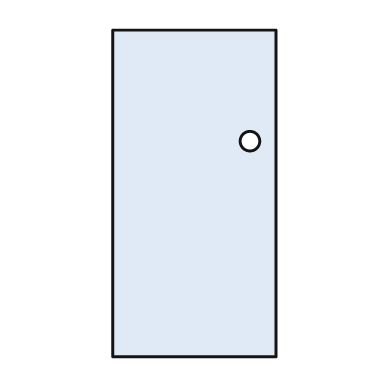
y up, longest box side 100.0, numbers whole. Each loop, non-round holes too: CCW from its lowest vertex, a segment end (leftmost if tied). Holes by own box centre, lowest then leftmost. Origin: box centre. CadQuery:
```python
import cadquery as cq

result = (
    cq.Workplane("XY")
    .moveTo(-25.0, -50.0)
    .lineTo(25.0, -50.0)
    .lineTo(25.0, 50.0)
    .lineTo(-25.0, 50.0)
    .close()
    .moveTo(17.0, 16.0)
    .circle(3.0)
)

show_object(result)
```